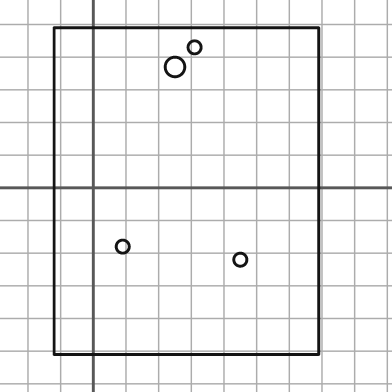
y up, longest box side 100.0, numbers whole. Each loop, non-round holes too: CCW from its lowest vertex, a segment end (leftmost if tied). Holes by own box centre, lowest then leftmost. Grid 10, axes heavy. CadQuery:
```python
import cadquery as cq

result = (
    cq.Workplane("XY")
    .moveTo(-12.0, -51.0)
    .lineTo(69.0, -51.0)
    .lineTo(69.0, 49.0)
    .lineTo(-12.0, 49.0)
    .close()
    .moveTo(45.0, -22.0)
    .circle(2.0)
    .moveTo(9.0, -18.0)
    .circle(2.0)
    .moveTo(25.0, 37.0)
    .circle(3.0)
    .moveTo(31.0, 43.0)
    .circle(2.0)
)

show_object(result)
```